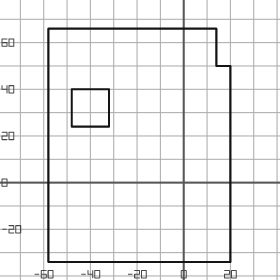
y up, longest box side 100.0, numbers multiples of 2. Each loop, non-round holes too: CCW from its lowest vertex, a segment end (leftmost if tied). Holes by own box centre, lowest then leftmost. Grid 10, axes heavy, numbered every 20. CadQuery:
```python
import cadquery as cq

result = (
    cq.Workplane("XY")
    .moveTo(-58.0, -34.0)
    .lineTo(20.0, -34.0)
    .lineTo(20.0, 50.0)
    .lineTo(14.0, 50.0)
    .lineTo(14.0, 66.0)
    .lineTo(-58.0, 66.0)
    .close()
    .moveTo(-48.0, 24.0)
    .lineTo(-32.0, 24.0)
    .lineTo(-32.0, 40.0)
    .lineTo(-48.0, 40.0)
    .close()
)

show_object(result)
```